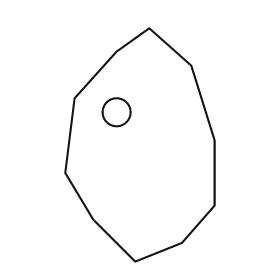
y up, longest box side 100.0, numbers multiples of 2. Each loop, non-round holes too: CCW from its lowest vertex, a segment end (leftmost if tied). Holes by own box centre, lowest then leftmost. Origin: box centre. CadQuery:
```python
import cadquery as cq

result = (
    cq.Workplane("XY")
    .moveTo(-2.0, -50.0)
    .lineTo(18.0, -42.0)
    .lineTo(32.0, -26.0)
    .lineTo(32.0, 2.0)
    .lineTo(22.0, 34.0)
    .lineTo(4.0, 50.0)
    .lineTo(-10.0, 40.0)
    .lineTo(-28.0, 20.0)
    .lineTo(-32.0, -12.0)
    .lineTo(-20.0, -32.0)
    .close()
    .moveTo(-10.0, 14.0)
    .circle(6.0)
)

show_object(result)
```